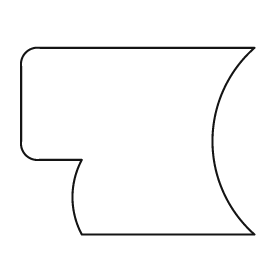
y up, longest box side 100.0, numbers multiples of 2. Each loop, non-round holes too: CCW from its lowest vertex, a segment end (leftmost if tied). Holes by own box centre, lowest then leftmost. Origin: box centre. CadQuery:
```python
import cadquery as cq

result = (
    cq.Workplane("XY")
    .moveTo(-24.0, -40.0)
    .lineTo(50.0, -40.0)
    .threePointArc((32.0, 0.0), (50.0, 40.0))
    .lineTo(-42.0, 40.0)
    .threePointArc((-48.0, 38.0), (-50.0, 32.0))
    .lineTo(-50.0, 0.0)
    .threePointArc((-48.0, -6.0), (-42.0, -8.0))
    .lineTo(-24.0, -8.0)
    .threePointArc((-28.0, -24.0), (-24.0, -40.0))
    .close()
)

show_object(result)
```